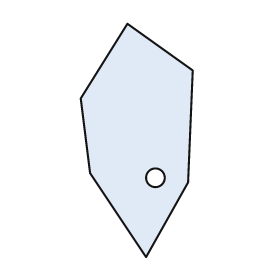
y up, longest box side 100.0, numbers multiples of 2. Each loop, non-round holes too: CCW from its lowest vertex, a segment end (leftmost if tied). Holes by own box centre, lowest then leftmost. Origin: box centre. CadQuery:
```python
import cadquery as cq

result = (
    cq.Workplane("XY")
    .moveTo(4.0, -50.0)
    .lineTo(22.0, -18.0)
    .lineTo(24.0, 30.0)
    .lineTo(-4.0, 50.0)
    .lineTo(-24.0, 18.0)
    .lineTo(-20.0, -14.0)
    .close()
    .moveTo(8.0, -16.0)
    .circle(4.0)
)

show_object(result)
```